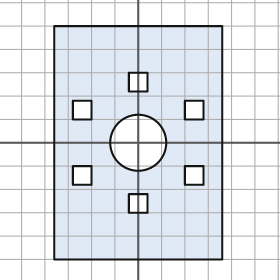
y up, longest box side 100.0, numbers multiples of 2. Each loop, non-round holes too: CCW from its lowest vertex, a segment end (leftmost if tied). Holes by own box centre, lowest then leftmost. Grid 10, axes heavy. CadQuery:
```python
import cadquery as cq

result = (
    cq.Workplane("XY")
    .moveTo(-36.0, -50.0)
    .lineTo(36.0, -50.0)
    .lineTo(36.0, 50.0)
    .lineTo(-36.0, 50.0)
    .close()
    .moveTo(-4.0, -30.0)
    .lineTo(4.0, -30.0)
    .lineTo(4.0, -22.0)
    .lineTo(-4.0, -22.0)
    .close()
    .moveTo(-28.0, -18.0)
    .lineTo(-20.0, -18.0)
    .lineTo(-20.0, -10.0)
    .lineTo(-28.0, -10.0)
    .close()
    .moveTo(20.0, -18.0)
    .lineTo(28.0, -18.0)
    .lineTo(28.0, -10.0)
    .lineTo(20.0, -10.0)
    .close()
    .moveTo(0.0, 0.0)
    .circle(12.0)
    .moveTo(-28.0, 10.0)
    .lineTo(-20.0, 10.0)
    .lineTo(-20.0, 18.0)
    .lineTo(-28.0, 18.0)
    .close()
    .moveTo(20.0, 10.0)
    .lineTo(28.0, 10.0)
    .lineTo(28.0, 18.0)
    .lineTo(20.0, 18.0)
    .close()
    .moveTo(-4.0, 22.0)
    .lineTo(4.0, 22.0)
    .lineTo(4.0, 30.0)
    .lineTo(-4.0, 30.0)
    .close()
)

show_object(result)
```